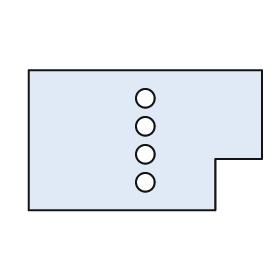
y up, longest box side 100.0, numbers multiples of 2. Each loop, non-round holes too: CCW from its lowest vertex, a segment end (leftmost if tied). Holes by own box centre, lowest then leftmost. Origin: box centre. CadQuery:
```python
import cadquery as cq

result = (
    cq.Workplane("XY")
    .moveTo(-50.0, -30.0)
    .lineTo(30.0, -30.0)
    .lineTo(30.0, -8.0)
    .lineTo(50.0, -8.0)
    .lineTo(50.0, 30.0)
    .lineTo(-50.0, 30.0)
    .close()
    .moveTo(0.0, -18.0)
    .circle(4.0)
    .moveTo(0.0, -6.0)
    .circle(4.0)
    .moveTo(0.0, 6.0)
    .circle(4.0)
    .moveTo(0.0, 18.0)
    .circle(4.0)
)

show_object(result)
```